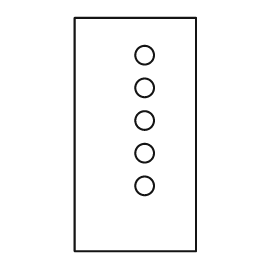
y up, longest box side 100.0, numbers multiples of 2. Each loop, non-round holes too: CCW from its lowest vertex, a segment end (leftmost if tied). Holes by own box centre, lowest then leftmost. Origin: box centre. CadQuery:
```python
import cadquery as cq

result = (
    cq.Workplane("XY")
    .moveTo(-26.0, -50.0)
    .lineTo(26.0, -50.0)
    .lineTo(26.0, 50.0)
    .lineTo(-26.0, 50.0)
    .close()
    .moveTo(4.0, -22.0)
    .circle(4.0)
    .moveTo(4.0, -8.0)
    .circle(4.0)
    .moveTo(4.0, 6.0)
    .circle(4.0)
    .moveTo(4.0, 20.0)
    .circle(4.0)
    .moveTo(4.0, 34.0)
    .circle(4.0)
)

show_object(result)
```